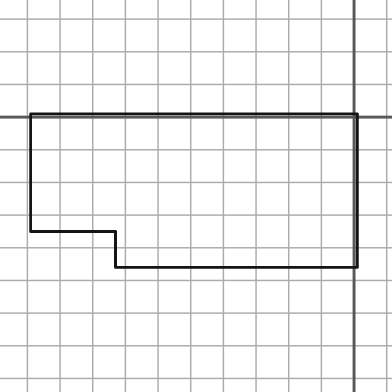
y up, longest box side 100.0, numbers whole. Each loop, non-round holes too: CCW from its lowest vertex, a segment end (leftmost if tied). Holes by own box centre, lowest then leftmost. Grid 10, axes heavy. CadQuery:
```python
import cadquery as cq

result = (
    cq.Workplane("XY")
    .moveTo(-73.0, -46.0)
    .lineTo(1.0, -46.0)
    .lineTo(1.0, 1.0)
    .lineTo(-99.0, 1.0)
    .lineTo(-99.0, -35.0)
    .lineTo(-73.0, -35.0)
    .close()
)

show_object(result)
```